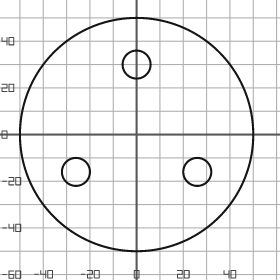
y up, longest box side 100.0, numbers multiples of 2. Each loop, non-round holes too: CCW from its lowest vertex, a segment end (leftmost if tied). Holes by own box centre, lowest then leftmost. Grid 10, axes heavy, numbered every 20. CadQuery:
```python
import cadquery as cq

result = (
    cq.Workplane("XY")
    .moveTo(0.0, 0.0)
    .circle(50.0)
    .moveTo(-26.0, -16.0)
    .circle(6.0)
    .moveTo(26.0, -16.0)
    .circle(6.0)
    .moveTo(0.0, 30.0)
    .circle(6.0)
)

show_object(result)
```